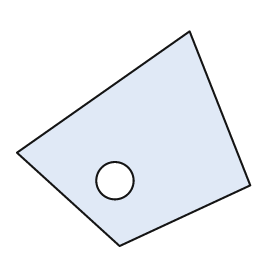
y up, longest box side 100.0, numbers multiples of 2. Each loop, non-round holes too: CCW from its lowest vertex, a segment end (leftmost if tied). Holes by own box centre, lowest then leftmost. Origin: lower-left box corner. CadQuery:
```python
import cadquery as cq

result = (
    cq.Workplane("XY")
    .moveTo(44.0, 0.0)
    .lineTo(100.0, 26.0)
    .lineTo(74.0, 92.0)
    .lineTo(0.0, 40.0)
    .close()
    .moveTo(42.0, 28.0)
    .circle(8.0)
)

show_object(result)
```